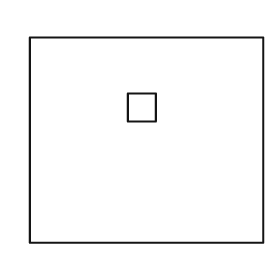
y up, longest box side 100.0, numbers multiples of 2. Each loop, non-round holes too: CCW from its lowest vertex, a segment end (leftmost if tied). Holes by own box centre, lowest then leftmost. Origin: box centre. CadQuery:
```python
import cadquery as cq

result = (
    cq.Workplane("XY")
    .moveTo(-50.0, -44.0)
    .lineTo(50.0, -44.0)
    .lineTo(50.0, 44.0)
    .lineTo(-50.0, 44.0)
    .close()
    .moveTo(-8.0, 8.0)
    .lineTo(4.0, 8.0)
    .lineTo(4.0, 20.0)
    .lineTo(-8.0, 20.0)
    .close()
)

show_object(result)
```